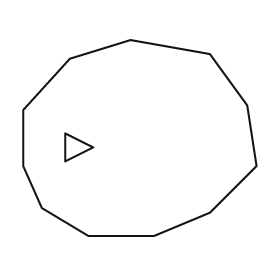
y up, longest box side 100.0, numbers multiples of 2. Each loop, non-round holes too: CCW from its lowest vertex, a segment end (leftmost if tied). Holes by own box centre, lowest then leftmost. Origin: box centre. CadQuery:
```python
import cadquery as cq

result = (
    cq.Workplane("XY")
    .moveTo(-22.0, -42.0)
    .lineTo(6.0, -42.0)
    .lineTo(30.0, -32.0)
    .lineTo(50.0, -12.0)
    .lineTo(46.0, 14.0)
    .lineTo(30.0, 36.0)
    .lineTo(-4.0, 42.0)
    .lineTo(-30.0, 34.0)
    .lineTo(-50.0, 12.0)
    .lineTo(-50.0, -12.0)
    .lineTo(-42.0, -30.0)
    .close()
    .moveTo(-32.0, -10.0)
    .lineTo(-20.0, -4.0)
    .lineTo(-32.0, 2.0)
    .close()
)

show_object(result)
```